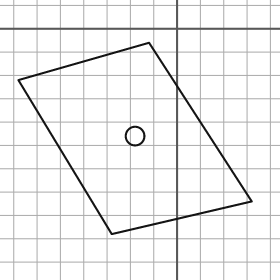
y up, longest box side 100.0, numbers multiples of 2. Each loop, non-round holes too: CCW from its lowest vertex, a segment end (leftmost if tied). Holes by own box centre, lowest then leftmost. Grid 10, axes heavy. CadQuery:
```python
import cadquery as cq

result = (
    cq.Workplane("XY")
    .moveTo(-28.0, -88.0)
    .lineTo(32.0, -74.0)
    .lineTo(-12.0, -6.0)
    .lineTo(-68.0, -22.0)
    .close()
    .moveTo(-18.0, -46.0)
    .circle(4.0)
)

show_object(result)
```